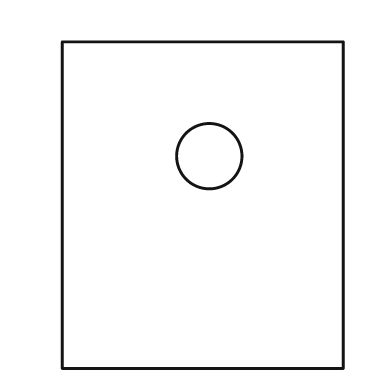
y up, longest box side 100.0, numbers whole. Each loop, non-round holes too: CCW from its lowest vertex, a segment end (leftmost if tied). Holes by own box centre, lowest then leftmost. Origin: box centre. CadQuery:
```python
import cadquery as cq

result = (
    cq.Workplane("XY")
    .moveTo(-43.0, -50.0)
    .lineTo(43.0, -50.0)
    .lineTo(43.0, 50.0)
    .lineTo(-43.0, 50.0)
    .close()
    .moveTo(2.0, 15.0)
    .circle(10.0)
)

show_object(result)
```